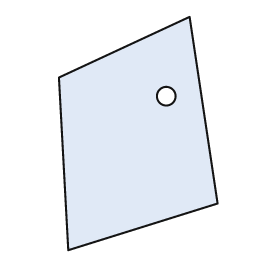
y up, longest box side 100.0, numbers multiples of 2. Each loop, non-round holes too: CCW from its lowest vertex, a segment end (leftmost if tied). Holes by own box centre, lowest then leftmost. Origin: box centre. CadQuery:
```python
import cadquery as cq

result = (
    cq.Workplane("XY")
    .moveTo(-30.0, -50.0)
    .lineTo(34.0, -30.0)
    .lineTo(22.0, 50.0)
    .lineTo(-34.0, 24.0)
    .close()
    .moveTo(12.0, 16.0)
    .circle(4.0)
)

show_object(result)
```